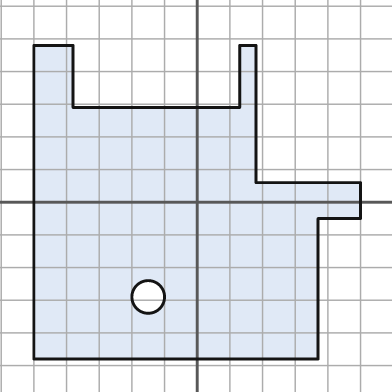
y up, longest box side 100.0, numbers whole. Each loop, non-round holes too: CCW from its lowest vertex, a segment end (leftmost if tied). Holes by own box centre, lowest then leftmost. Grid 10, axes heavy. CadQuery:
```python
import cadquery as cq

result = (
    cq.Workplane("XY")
    .moveTo(-50.0, -48.0)
    .lineTo(37.0, -48.0)
    .lineTo(37.0, -5.0)
    .lineTo(50.0, -5.0)
    .lineTo(50.0, 6.0)
    .lineTo(18.0, 6.0)
    .lineTo(18.0, 48.0)
    .lineTo(13.0, 48.0)
    .lineTo(13.0, 29.0)
    .lineTo(-38.0, 29.0)
    .lineTo(-38.0, 48.0)
    .lineTo(-50.0, 48.0)
    .close()
    .moveTo(-15.0, -29.0)
    .circle(5.0)
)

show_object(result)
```